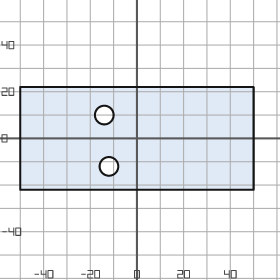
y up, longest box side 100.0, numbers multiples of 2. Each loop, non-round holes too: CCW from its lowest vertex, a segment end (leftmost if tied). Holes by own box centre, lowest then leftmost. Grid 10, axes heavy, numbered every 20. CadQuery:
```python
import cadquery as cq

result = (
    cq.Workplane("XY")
    .moveTo(-50.0, -22.0)
    .lineTo(50.0, -22.0)
    .lineTo(50.0, 22.0)
    .lineTo(-50.0, 22.0)
    .close()
    .moveTo(-12.0, -12.0)
    .circle(4.0)
    .moveTo(-14.0, 10.0)
    .circle(4.0)
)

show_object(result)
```